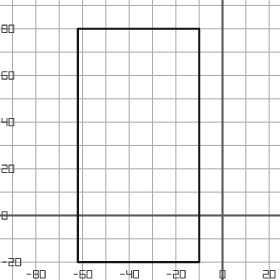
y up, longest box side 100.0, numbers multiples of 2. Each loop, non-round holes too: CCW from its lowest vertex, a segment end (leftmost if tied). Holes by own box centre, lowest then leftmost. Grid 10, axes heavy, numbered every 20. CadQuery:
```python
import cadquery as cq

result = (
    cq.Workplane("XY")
    .moveTo(-62.0, -20.0)
    .lineTo(-10.0, -20.0)
    .lineTo(-10.0, 80.0)
    .lineTo(-62.0, 80.0)
    .close()
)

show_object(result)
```